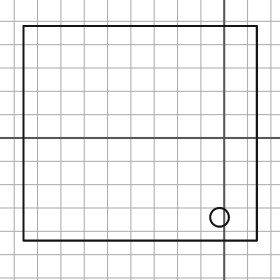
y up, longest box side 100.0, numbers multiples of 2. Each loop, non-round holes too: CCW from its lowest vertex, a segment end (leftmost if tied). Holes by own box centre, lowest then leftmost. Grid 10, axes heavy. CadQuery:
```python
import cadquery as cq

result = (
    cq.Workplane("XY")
    .moveTo(-86.0, -44.0)
    .lineTo(14.0, -44.0)
    .lineTo(14.0, 48.0)
    .lineTo(-86.0, 48.0)
    .close()
    .moveTo(-2.0, -34.0)
    .circle(4.0)
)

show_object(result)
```